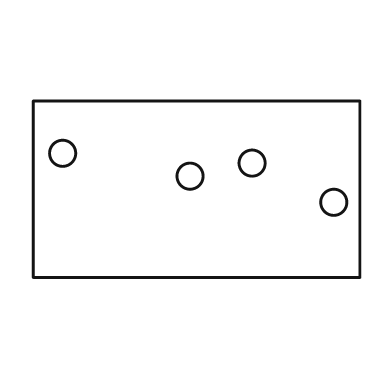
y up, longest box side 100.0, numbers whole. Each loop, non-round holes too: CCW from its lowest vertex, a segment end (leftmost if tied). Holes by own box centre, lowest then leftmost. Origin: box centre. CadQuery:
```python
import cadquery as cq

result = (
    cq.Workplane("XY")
    .moveTo(-50.0, -27.0)
    .lineTo(50.0, -27.0)
    .lineTo(50.0, 27.0)
    .lineTo(-50.0, 27.0)
    .close()
    .moveTo(42.0, -4.0)
    .circle(4.0)
    .moveTo(-2.0, 4.0)
    .circle(4.0)
    .moveTo(17.0, 8.0)
    .circle(4.0)
    .moveTo(-41.0, 11.0)
    .circle(4.0)
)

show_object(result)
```